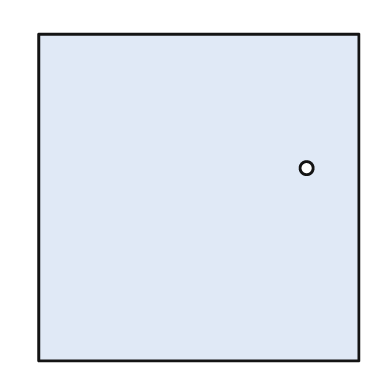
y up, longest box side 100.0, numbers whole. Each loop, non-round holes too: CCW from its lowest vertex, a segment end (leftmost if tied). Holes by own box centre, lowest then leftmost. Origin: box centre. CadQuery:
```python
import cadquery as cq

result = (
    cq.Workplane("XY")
    .moveTo(-49.0, -50.0)
    .lineTo(49.0, -50.0)
    .lineTo(49.0, 50.0)
    .lineTo(-49.0, 50.0)
    .close()
    .moveTo(33.0, 9.0)
    .circle(2.0)
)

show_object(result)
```